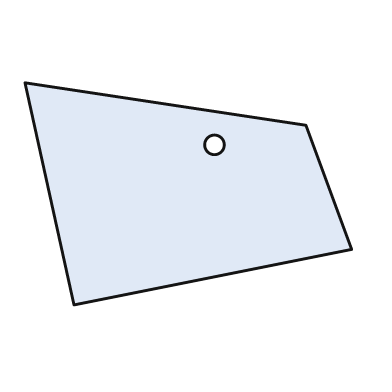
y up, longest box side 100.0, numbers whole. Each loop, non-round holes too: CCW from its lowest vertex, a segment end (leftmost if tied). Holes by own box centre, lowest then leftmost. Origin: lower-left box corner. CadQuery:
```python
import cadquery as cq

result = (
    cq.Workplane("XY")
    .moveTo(15.0, 0.0)
    .lineTo(100.0, 17.0)
    .lineTo(86.0, 55.0)
    .lineTo(0.0, 68.0)
    .close()
    .moveTo(58.0, 49.0)
    .circle(3.0)
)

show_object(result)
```